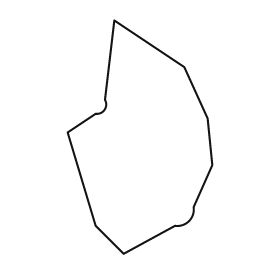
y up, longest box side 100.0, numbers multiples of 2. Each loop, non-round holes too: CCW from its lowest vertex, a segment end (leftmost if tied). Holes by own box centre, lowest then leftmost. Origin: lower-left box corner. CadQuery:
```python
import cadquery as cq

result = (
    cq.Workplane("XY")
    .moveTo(24.0, 0.0)
    .lineTo(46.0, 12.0)
    .threePointArc((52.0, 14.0), (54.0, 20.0))
    .lineTo(62.0, 38.0)
    .lineTo(60.0, 58.0)
    .lineTo(50.0, 80.0)
    .lineTo(20.0, 100.0)
    .lineTo(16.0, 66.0)
    .threePointArc((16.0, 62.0), (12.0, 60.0))
    .lineTo(0.0, 52.0)
    .lineTo(12.0, 12.0)
    .close()
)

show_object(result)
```